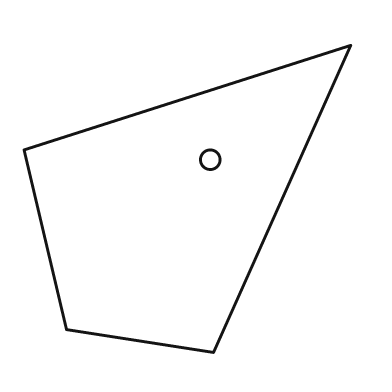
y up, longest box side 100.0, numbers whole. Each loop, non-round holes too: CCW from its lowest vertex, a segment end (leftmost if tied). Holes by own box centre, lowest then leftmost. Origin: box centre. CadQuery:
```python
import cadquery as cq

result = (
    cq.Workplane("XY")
    .moveTo(8.0, -47.0)
    .lineTo(50.0, 47.0)
    .lineTo(-50.0, 15.0)
    .lineTo(-37.0, -40.0)
    .close()
    .moveTo(7.0, 12.0)
    .circle(3.0)
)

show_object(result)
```